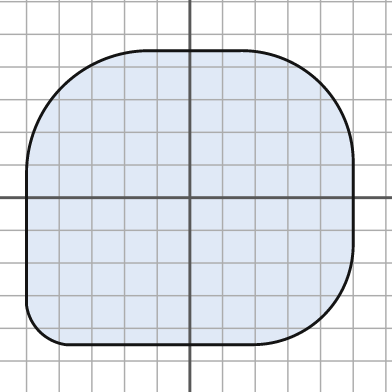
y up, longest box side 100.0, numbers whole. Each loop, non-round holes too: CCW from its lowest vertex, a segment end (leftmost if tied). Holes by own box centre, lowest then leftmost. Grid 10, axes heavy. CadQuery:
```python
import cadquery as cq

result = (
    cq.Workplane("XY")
    .moveTo(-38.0, -45.0)
    .lineTo(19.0, -45.0)
    .threePointArc((41.0, -36.0), (50.0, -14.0))
    .lineTo(50.0, 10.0)
    .threePointArc((40.0, 35.0), (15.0, 45.0))
    .lineTo(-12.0, 45.0)
    .threePointArc((-39.0, 34.0), (-50.0, 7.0))
    .lineTo(-50.0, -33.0)
    .threePointArc((-46.0, -41.0), (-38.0, -45.0))
    .close()
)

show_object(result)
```